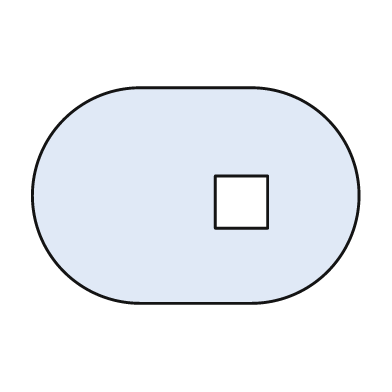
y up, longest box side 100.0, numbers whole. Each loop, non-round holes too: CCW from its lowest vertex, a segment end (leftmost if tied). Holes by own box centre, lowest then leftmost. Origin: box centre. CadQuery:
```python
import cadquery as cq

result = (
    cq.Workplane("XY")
    .moveTo(-17.0, -33.0)
    .lineTo(17.0, -33.0)
    .threePointArc((50.0, 0.0), (17.0, 33.0))
    .lineTo(-17.0, 33.0)
    .threePointArc((-50.0, 0.0), (-17.0, -33.0))
    .close()
    .moveTo(6.0, -10.0)
    .lineTo(22.0, -10.0)
    .lineTo(22.0, 6.0)
    .lineTo(6.0, 6.0)
    .close()
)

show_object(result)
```